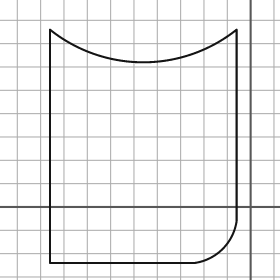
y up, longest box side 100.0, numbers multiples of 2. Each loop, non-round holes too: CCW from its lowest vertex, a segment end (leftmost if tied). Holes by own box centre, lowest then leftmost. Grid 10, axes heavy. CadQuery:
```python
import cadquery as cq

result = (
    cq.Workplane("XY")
    .moveTo(-86.0, -24.0)
    .lineTo(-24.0, -24.0)
    .threePointArc((-12.0, -18.0), (-6.0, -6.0))
    .lineTo(-6.0, 76.0)
    .threePointArc((-46.0, 62.0), (-86.0, 76.0))
    .close()
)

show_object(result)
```